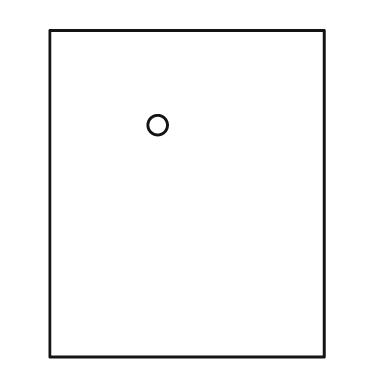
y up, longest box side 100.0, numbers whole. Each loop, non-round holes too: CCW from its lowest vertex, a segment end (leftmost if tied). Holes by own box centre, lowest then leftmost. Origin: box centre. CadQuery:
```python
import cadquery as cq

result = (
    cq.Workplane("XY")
    .moveTo(-42.0, -50.0)
    .lineTo(42.0, -50.0)
    .lineTo(42.0, 50.0)
    .lineTo(-42.0, 50.0)
    .close()
    .moveTo(-9.0, 21.0)
    .circle(3.0)
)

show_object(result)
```